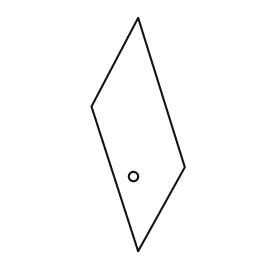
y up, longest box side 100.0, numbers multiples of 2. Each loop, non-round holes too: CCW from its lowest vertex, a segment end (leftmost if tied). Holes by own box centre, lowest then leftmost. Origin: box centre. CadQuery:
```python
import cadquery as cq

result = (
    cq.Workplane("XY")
    .moveTo(0.0, -50.0)
    .lineTo(20.0, -14.0)
    .lineTo(0.0, 50.0)
    .lineTo(-20.0, 12.0)
    .close()
    .moveTo(-2.0, -18.0)
    .circle(2.0)
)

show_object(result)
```